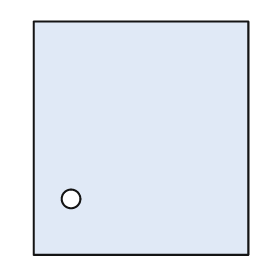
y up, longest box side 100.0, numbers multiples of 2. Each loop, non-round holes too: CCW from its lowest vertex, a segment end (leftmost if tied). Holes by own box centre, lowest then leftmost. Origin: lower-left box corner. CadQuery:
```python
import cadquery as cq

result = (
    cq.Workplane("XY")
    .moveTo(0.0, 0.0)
    .lineTo(92.0, 0.0)
    .lineTo(92.0, 100.0)
    .lineTo(0.0, 100.0)
    .close()
    .moveTo(16.0, 24.0)
    .circle(4.0)
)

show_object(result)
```